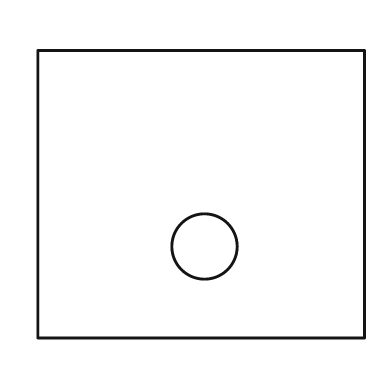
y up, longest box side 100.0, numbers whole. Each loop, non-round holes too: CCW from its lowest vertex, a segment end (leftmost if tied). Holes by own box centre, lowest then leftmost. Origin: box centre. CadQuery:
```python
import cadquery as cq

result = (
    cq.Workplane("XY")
    .moveTo(-50.0, -44.0)
    .lineTo(50.0, -44.0)
    .lineTo(50.0, 44.0)
    .lineTo(-50.0, 44.0)
    .close()
    .moveTo(1.0, -16.0)
    .circle(10.0)
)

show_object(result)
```